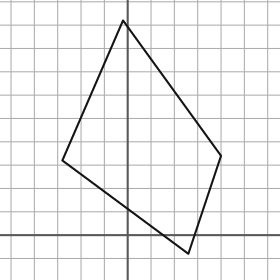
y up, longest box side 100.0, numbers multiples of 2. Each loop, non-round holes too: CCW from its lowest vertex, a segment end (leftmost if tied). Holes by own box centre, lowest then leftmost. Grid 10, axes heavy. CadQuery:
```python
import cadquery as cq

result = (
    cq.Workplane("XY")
    .moveTo(26.0, -8.0)
    .lineTo(40.0, 34.0)
    .lineTo(-2.0, 92.0)
    .lineTo(-28.0, 32.0)
    .close()
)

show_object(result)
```